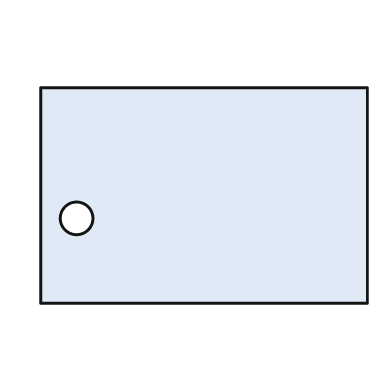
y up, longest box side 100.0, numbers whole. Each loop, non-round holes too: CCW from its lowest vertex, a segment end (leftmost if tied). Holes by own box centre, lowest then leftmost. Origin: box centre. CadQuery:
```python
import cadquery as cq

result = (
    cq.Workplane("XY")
    .moveTo(-50.0, -33.0)
    .lineTo(50.0, -33.0)
    .lineTo(50.0, 33.0)
    .lineTo(-50.0, 33.0)
    .close()
    .moveTo(-39.0, -7.0)
    .circle(5.0)
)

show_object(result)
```